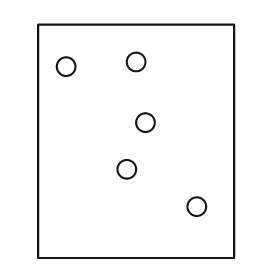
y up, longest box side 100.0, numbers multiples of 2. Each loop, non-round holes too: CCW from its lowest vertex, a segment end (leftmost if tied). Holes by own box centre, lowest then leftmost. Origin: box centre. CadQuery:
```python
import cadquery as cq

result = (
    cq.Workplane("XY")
    .moveTo(-42.0, -50.0)
    .lineTo(42.0, -50.0)
    .lineTo(42.0, 50.0)
    .lineTo(-42.0, 50.0)
    .close()
    .moveTo(26.0, -28.0)
    .circle(4.0)
    .moveTo(-4.0, -12.0)
    .circle(4.0)
    .moveTo(4.0, 8.0)
    .circle(4.0)
    .moveTo(-30.0, 32.0)
    .circle(4.0)
    .moveTo(0.0, 34.0)
    .circle(4.0)
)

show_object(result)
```